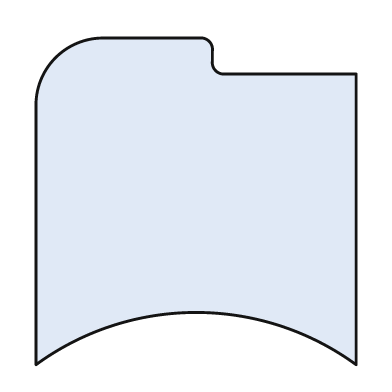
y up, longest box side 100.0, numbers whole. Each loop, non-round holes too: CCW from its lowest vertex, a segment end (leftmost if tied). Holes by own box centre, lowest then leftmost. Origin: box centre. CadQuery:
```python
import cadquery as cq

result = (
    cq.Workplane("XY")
    .moveTo(-49.0, -50.0)
    .threePointArc((0.0, -34.0), (49.0, -50.0))
    .lineTo(49.0, 39.0)
    .lineTo(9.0, 39.0)
    .threePointArc((6.0, 40.0), (5.0, 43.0))
    .lineTo(5.0, 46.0)
    .threePointArc((4.0, 49.0), (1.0, 50.0))
    .lineTo(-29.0, 50.0)
    .threePointArc((-43.0, 44.0), (-49.0, 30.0))
    .close()
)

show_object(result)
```